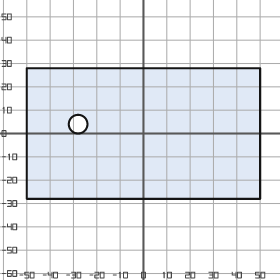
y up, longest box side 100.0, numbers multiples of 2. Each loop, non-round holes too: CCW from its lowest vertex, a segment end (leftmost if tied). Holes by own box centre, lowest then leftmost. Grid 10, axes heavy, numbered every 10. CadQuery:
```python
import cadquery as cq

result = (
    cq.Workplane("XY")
    .moveTo(-50.0, -28.0)
    .lineTo(50.0, -28.0)
    .lineTo(50.0, 28.0)
    .lineTo(-50.0, 28.0)
    .close()
    .moveTo(-28.0, 4.0)
    .circle(4.0)
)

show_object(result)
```